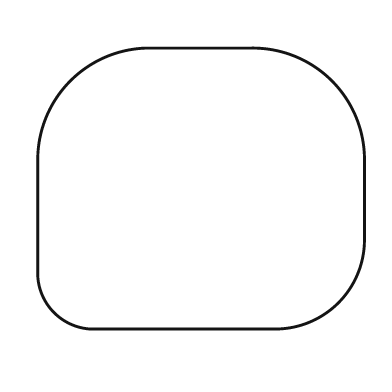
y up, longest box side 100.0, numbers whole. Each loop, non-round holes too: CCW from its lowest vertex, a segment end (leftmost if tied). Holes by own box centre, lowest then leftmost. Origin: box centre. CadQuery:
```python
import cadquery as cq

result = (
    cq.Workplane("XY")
    .moveTo(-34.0, -43.0)
    .lineTo(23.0, -43.0)
    .threePointArc((42.0, -35.0), (50.0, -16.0))
    .lineTo(50.0, 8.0)
    .threePointArc((40.0, 33.0), (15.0, 43.0))
    .lineTo(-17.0, 43.0)
    .threePointArc((-40.0, 33.0), (-50.0, 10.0))
    .lineTo(-50.0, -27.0)
    .threePointArc((-45.0, -38.0), (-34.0, -43.0))
    .close()
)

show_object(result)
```